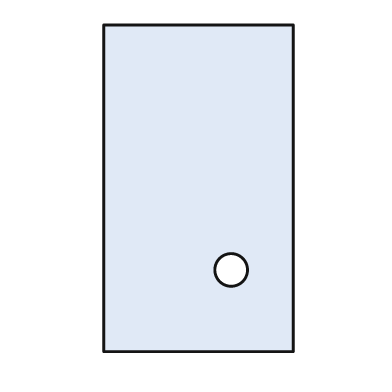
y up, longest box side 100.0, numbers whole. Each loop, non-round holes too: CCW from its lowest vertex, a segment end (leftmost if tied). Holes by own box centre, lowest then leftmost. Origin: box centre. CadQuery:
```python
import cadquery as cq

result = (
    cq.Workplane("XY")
    .moveTo(-29.0, -50.0)
    .lineTo(29.0, -50.0)
    .lineTo(29.0, 50.0)
    .lineTo(-29.0, 50.0)
    .close()
    .moveTo(10.0, -25.0)
    .circle(5.0)
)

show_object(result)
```